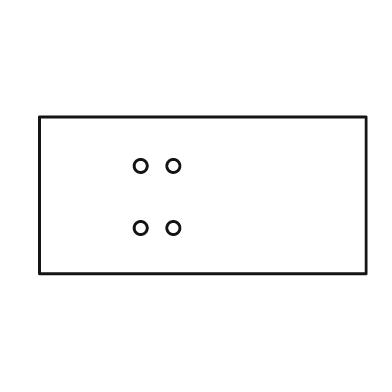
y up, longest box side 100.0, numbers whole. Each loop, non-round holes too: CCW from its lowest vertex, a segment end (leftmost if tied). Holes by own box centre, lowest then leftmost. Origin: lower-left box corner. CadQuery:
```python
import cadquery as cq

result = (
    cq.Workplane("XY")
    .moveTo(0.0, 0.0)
    .lineTo(100.0, 0.0)
    .lineTo(100.0, 48.0)
    .lineTo(0.0, 48.0)
    .close()
    .moveTo(31.0, 14.0)
    .circle(2.0)
    .moveTo(41.0, 14.0)
    .circle(2.0)
    .moveTo(31.0, 33.0)
    .circle(2.0)
    .moveTo(41.0, 33.0)
    .circle(2.0)
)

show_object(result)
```